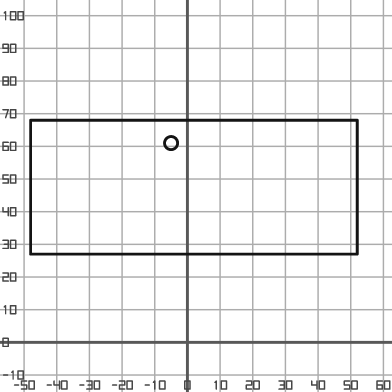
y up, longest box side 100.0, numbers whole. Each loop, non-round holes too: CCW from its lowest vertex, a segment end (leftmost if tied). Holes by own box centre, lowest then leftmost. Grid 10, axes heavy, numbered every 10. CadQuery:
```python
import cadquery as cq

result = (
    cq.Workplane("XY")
    .moveTo(-48.0, 27.0)
    .lineTo(52.0, 27.0)
    .lineTo(52.0, 68.0)
    .lineTo(-48.0, 68.0)
    .close()
    .moveTo(-5.0, 61.0)
    .circle(2.0)
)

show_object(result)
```